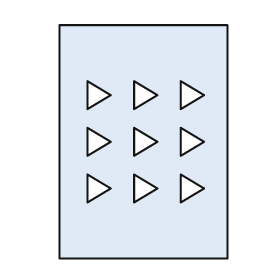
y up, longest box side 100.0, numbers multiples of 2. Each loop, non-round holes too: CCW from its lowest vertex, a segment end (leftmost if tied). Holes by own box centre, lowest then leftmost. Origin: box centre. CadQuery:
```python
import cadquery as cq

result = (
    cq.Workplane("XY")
    .moveTo(-36.0, -50.0)
    .lineTo(36.0, -50.0)
    .lineTo(36.0, 50.0)
    .lineTo(-36.0, 50.0)
    .close()
    .moveTo(-24.0, -26.0)
    .lineTo(-14.0, -20.0)
    .lineTo(-24.0, -14.0)
    .close()
    .moveTo(-4.0, -26.0)
    .lineTo(6.0, -20.0)
    .lineTo(-4.0, -14.0)
    .close()
    .moveTo(16.0, -26.0)
    .lineTo(26.0, -20.0)
    .lineTo(16.0, -14.0)
    .close()
    .moveTo(-24.0, -6.0)
    .lineTo(-14.0, 0.0)
    .lineTo(-24.0, 6.0)
    .close()
    .moveTo(-4.0, -6.0)
    .lineTo(6.0, 0.0)
    .lineTo(-4.0, 6.0)
    .close()
    .moveTo(16.0, -6.0)
    .lineTo(26.0, 0.0)
    .lineTo(16.0, 6.0)
    .close()
    .moveTo(-24.0, 14.0)
    .lineTo(-14.0, 20.0)
    .lineTo(-24.0, 26.0)
    .close()
    .moveTo(-4.0, 14.0)
    .lineTo(6.0, 20.0)
    .lineTo(-4.0, 26.0)
    .close()
    .moveTo(16.0, 14.0)
    .lineTo(26.0, 20.0)
    .lineTo(16.0, 26.0)
    .close()
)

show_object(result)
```